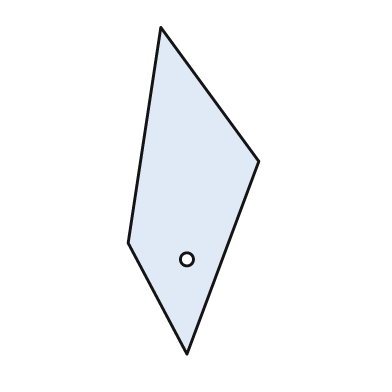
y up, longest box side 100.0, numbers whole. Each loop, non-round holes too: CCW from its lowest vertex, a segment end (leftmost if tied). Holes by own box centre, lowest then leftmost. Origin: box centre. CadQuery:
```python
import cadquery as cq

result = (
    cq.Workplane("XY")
    .moveTo(-2.0, -50.0)
    .lineTo(20.0, 9.0)
    .lineTo(-10.0, 50.0)
    .lineTo(-20.0, -16.0)
    .close()
    .moveTo(-2.0, -21.0)
    .circle(2.0)
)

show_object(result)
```